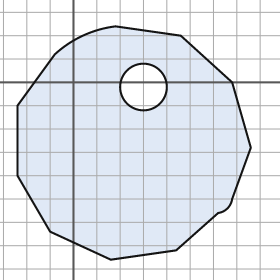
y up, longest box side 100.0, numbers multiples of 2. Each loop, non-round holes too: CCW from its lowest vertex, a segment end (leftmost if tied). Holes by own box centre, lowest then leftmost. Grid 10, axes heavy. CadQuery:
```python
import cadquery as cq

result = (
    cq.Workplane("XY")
    .moveTo(16.0, -76.0)
    .lineTo(44.0, -72.0)
    .lineTo(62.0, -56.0)
    .threePointArc((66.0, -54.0), (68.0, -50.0))
    .lineTo(76.0, -28.0)
    .lineTo(68.0, 0.0)
    .lineTo(46.0, 20.0)
    .lineTo(18.0, 24.0)
    .threePointArc((4.0, 20.0), (-8.0, 12.0))
    .lineTo(-24.0, -10.0)
    .lineTo(-24.0, -40.0)
    .lineTo(-10.0, -64.0)
    .close()
    .moveTo(30.0, -2.0)
    .circle(10.0)
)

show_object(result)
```